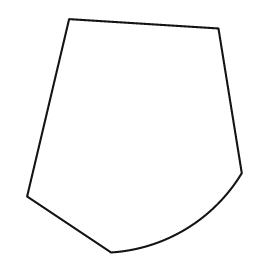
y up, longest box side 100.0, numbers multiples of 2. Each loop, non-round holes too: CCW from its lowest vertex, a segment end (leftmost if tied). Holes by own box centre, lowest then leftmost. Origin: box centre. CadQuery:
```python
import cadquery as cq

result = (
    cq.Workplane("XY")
    .moveTo(-10.0, -50.0)
    .threePointArc((22.0, -40.0), (46.0, -16.0))
    .lineTo(36.0, 46.0)
    .lineTo(-28.0, 50.0)
    .lineTo(-46.0, -26.0)
    .close()
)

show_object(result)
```